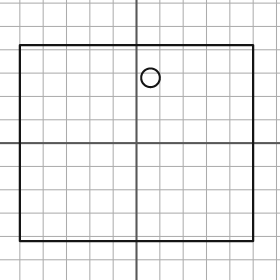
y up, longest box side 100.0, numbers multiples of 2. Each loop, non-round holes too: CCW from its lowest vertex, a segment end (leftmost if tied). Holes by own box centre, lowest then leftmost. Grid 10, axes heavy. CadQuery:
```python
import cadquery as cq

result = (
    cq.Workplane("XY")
    .moveTo(-50.0, -42.0)
    .lineTo(50.0, -42.0)
    .lineTo(50.0, 42.0)
    .lineTo(-50.0, 42.0)
    .close()
    .moveTo(6.0, 28.0)
    .circle(4.0)
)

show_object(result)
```